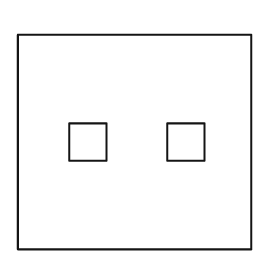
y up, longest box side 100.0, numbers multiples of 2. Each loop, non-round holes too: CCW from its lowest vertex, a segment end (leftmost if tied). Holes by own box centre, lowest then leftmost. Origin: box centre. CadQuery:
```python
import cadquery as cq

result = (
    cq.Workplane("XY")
    .moveTo(-50.0, -46.0)
    .lineTo(50.0, -46.0)
    .lineTo(50.0, 46.0)
    .lineTo(-50.0, 46.0)
    .close()
    .moveTo(-28.0, -8.0)
    .lineTo(-12.0, -8.0)
    .lineTo(-12.0, 8.0)
    .lineTo(-28.0, 8.0)
    .close()
    .moveTo(14.0, -8.0)
    .lineTo(30.0, -8.0)
    .lineTo(30.0, 8.0)
    .lineTo(14.0, 8.0)
    .close()
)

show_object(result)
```